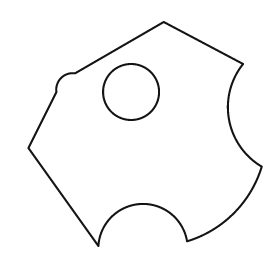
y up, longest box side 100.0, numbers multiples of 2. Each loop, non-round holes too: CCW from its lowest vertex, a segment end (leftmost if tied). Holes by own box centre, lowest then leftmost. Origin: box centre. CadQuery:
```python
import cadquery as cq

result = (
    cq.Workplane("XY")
    .moveTo(-20.0, -48.0)
    .threePointArc((-2.0, -30.0), (18.0, -46.0))
    .threePointArc((38.0, -34.0), (50.0, -14.0))
    .threePointArc((36.0, 6.0), (42.0, 30.0))
    .lineTo(8.0, 48.0)
    .lineTo(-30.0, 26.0)
    .threePointArc((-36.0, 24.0), (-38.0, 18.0))
    .lineTo(-50.0, -6.0)
    .close()
    .moveTo(-6.0, 18.0)
    .circle(12.0)
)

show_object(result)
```